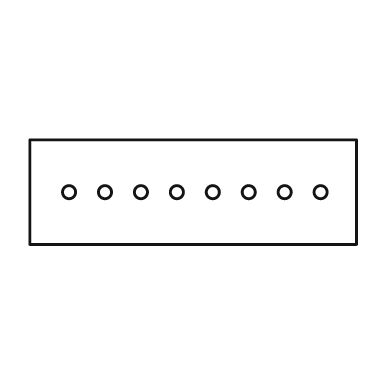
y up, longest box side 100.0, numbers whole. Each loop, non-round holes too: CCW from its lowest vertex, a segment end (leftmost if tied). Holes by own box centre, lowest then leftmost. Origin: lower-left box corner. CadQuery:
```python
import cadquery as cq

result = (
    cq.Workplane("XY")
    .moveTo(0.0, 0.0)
    .lineTo(100.0, 0.0)
    .lineTo(100.0, 32.0)
    .lineTo(0.0, 32.0)
    .close()
    .moveTo(12.0, 16.0)
    .circle(2.0)
    .moveTo(23.0, 16.0)
    .circle(2.0)
    .moveTo(34.0, 16.0)
    .circle(2.0)
    .moveTo(45.0, 16.0)
    .circle(2.0)
    .moveTo(56.0, 16.0)
    .circle(2.0)
    .moveTo(67.0, 16.0)
    .circle(2.0)
    .moveTo(78.0, 16.0)
    .circle(2.0)
    .moveTo(89.0, 16.0)
    .circle(2.0)
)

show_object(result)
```